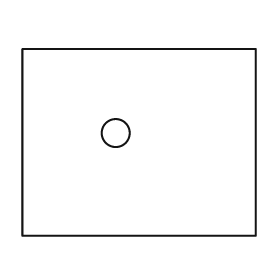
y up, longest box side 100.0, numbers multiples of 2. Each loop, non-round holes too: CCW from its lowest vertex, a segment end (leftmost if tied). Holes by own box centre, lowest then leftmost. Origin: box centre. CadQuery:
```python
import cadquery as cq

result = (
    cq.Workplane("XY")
    .moveTo(-50.0, -40.0)
    .lineTo(50.0, -40.0)
    .lineTo(50.0, 40.0)
    .lineTo(-50.0, 40.0)
    .close()
    .moveTo(-10.0, 4.0)
    .circle(6.0)
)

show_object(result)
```